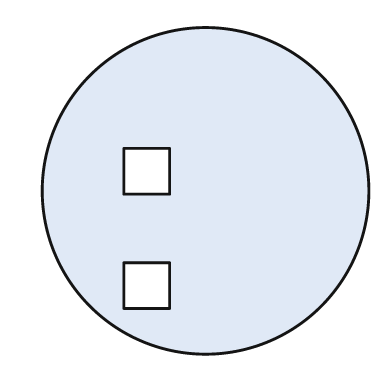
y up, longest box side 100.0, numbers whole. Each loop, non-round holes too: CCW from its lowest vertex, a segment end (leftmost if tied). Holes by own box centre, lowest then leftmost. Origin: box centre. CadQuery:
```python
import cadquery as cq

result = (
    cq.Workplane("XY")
    .moveTo(0.0, 0.0)
    .circle(50.0)
    .moveTo(-25.0, -36.0)
    .lineTo(-11.0, -36.0)
    .lineTo(-11.0, -22.0)
    .lineTo(-25.0, -22.0)
    .close()
    .moveTo(-25.0, -1.0)
    .lineTo(-11.0, -1.0)
    .lineTo(-11.0, 13.0)
    .lineTo(-25.0, 13.0)
    .close()
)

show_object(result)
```